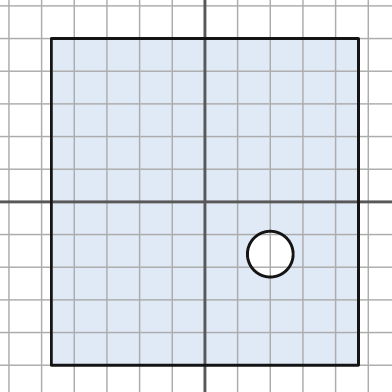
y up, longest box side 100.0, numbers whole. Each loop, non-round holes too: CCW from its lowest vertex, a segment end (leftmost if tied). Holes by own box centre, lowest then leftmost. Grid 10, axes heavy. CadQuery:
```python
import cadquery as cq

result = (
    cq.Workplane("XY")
    .moveTo(-47.0, -50.0)
    .lineTo(47.0, -50.0)
    .lineTo(47.0, 50.0)
    .lineTo(-47.0, 50.0)
    .close()
    .moveTo(20.0, -16.0)
    .circle(7.0)
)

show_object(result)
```